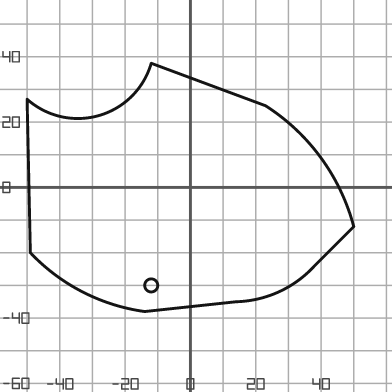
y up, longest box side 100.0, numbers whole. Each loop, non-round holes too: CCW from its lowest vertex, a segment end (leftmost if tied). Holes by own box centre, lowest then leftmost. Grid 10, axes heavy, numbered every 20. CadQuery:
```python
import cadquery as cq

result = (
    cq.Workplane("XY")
    .moveTo(-14.0, -38.0)
    .lineTo(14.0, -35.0)
    .threePointArc((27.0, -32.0), (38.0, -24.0))
    .lineTo(50.0, -12.0)
    .threePointArc((40.0, 9.0), (23.0, 25.0))
    .lineTo(-12.0, 38.0)
    .threePointArc((-28.0, 22.0), (-50.0, 27.0))
    .lineTo(-49.0, -20.0)
    .threePointArc((-33.0, -32.0), (-14.0, -38.0))
    .close()
    .moveTo(-12.0, -30.0)
    .circle(2.0)
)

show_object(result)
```